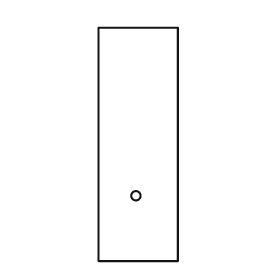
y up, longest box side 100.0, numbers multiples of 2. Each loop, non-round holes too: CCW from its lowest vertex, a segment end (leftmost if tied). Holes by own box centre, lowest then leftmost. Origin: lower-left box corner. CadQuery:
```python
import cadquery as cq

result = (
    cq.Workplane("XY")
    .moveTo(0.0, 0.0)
    .lineTo(34.0, 0.0)
    .lineTo(34.0, 100.0)
    .lineTo(0.0, 100.0)
    .close()
    .moveTo(16.0, 28.0)
    .circle(2.0)
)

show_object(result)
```